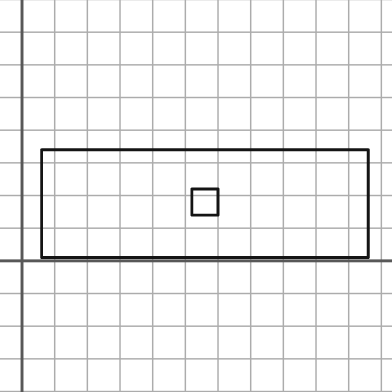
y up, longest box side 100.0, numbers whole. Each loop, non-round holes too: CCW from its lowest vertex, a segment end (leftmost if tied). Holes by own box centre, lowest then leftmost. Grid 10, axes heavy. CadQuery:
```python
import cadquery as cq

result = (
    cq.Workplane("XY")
    .moveTo(6.0, 1.0)
    .lineTo(106.0, 1.0)
    .lineTo(106.0, 34.0)
    .lineTo(6.0, 34.0)
    .close()
    .moveTo(52.0, 14.0)
    .lineTo(60.0, 14.0)
    .lineTo(60.0, 22.0)
    .lineTo(52.0, 22.0)
    .close()
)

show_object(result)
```